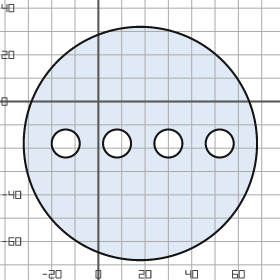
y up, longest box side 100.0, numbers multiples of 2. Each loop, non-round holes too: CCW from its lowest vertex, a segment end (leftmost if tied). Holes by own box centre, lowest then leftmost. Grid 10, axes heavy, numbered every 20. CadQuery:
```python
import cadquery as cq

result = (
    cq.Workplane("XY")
    .moveTo(18.0, -18.0)
    .circle(50.0)
    .moveTo(-14.0, -18.0)
    .circle(6.0)
    .moveTo(8.0, -18.0)
    .circle(6.0)
    .moveTo(30.0, -18.0)
    .circle(6.0)
    .moveTo(52.0, -18.0)
    .circle(6.0)
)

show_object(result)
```